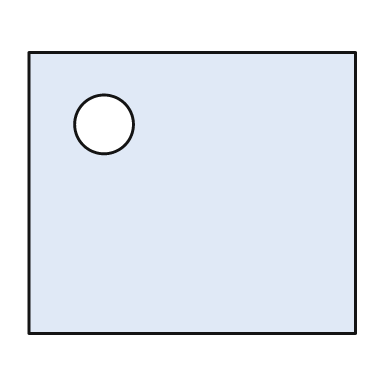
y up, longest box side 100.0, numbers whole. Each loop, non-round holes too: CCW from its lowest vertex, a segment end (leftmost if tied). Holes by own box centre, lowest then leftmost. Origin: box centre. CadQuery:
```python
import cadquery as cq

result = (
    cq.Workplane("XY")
    .moveTo(-50.0, -43.0)
    .lineTo(50.0, -43.0)
    .lineTo(50.0, 43.0)
    .lineTo(-50.0, 43.0)
    .close()
    .moveTo(-27.0, 21.0)
    .circle(9.0)
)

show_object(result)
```